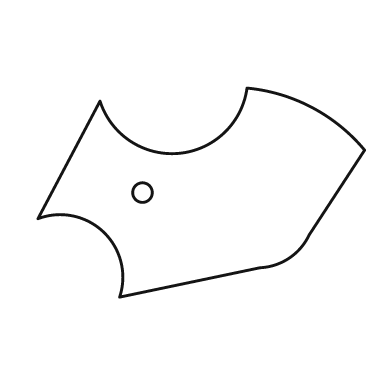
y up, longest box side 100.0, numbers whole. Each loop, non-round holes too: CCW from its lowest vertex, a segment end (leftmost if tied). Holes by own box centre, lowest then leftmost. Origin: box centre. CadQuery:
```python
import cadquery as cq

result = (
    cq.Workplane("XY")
    .moveTo(-25.0, -32.0)
    .lineTo(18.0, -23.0)
    .threePointArc((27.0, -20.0), (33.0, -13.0))
    .lineTo(50.0, 13.0)
    .threePointArc((34.0, 26.0), (14.0, 32.0))
    .threePointArc((-7.0, 12.0), (-31.0, 28.0))
    .lineTo(-50.0, -8.0)
    .threePointArc((-30.0, -12.0), (-25.0, -32.0))
    .close()
    .moveTo(-18.0, 0.0)
    .circle(3.0)
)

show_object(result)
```